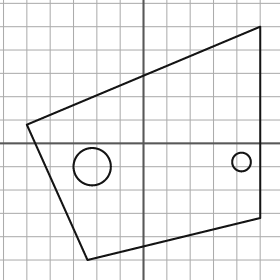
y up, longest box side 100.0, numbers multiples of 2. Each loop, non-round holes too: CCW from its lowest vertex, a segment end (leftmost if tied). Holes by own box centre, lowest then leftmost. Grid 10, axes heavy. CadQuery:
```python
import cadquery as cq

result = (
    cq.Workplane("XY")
    .moveTo(-24.0, -50.0)
    .lineTo(50.0, -32.0)
    .lineTo(50.0, 50.0)
    .lineTo(-50.0, 8.0)
    .close()
    .moveTo(-22.0, -10.0)
    .circle(8.0)
    .moveTo(42.0, -8.0)
    .circle(4.0)
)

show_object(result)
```